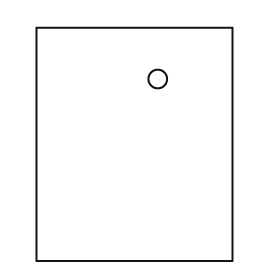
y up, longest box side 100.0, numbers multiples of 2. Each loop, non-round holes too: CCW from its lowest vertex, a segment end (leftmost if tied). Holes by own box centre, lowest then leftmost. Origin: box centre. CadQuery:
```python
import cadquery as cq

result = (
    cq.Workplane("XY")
    .moveTo(-42.0, -50.0)
    .lineTo(42.0, -50.0)
    .lineTo(42.0, 50.0)
    .lineTo(-42.0, 50.0)
    .close()
    .moveTo(10.0, 28.0)
    .circle(4.0)
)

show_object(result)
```